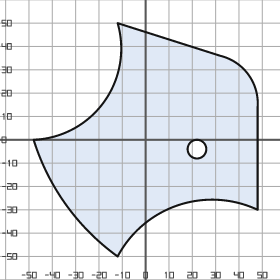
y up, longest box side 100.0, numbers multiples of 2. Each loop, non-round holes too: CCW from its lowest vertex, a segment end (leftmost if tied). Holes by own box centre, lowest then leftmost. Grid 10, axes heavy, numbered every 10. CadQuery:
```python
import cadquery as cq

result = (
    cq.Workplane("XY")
    .moveTo(-12.0, -50.0)
    .threePointArc((14.0, -28.0), (48.0, -30.0))
    .lineTo(48.0, 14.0)
    .threePointArc((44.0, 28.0), (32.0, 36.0))
    .lineTo(-12.0, 50.0)
    .threePointArc((-18.0, 16.0), (-48.0, 0.0))
    .threePointArc((-34.0, -28.0), (-12.0, -50.0))
    .close()
    .moveTo(22.0, -4.0)
    .circle(4.0)
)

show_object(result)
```